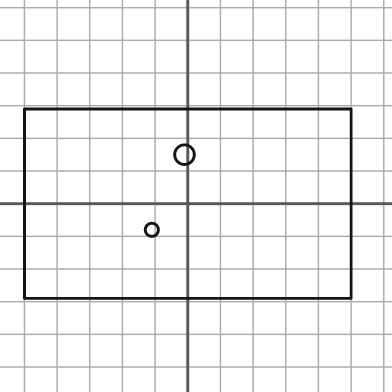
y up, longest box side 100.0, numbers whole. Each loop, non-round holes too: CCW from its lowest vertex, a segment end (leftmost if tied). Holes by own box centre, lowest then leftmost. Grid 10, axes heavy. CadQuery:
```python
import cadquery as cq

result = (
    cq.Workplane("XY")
    .moveTo(-50.0, -29.0)
    .lineTo(50.0, -29.0)
    .lineTo(50.0, 29.0)
    .lineTo(-50.0, 29.0)
    .close()
    .moveTo(-11.0, -8.0)
    .circle(2.0)
    .moveTo(-1.0, 15.0)
    .circle(3.0)
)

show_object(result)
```